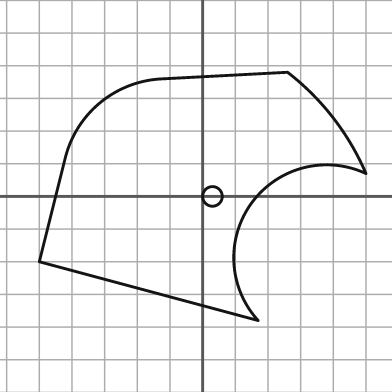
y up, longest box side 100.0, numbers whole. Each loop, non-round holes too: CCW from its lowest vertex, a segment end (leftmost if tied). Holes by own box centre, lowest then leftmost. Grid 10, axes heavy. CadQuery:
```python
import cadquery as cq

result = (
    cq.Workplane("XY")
    .moveTo(17.0, -38.0)
    .threePointArc((15.0, -2.0), (50.0, 7.0))
    .threePointArc((40.0, 24.0), (26.0, 38.0))
    .lineTo(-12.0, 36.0)
    .threePointArc((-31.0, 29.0), (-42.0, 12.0))
    .lineTo(-50.0, -20.0)
    .close()
    .moveTo(3.0, 0.0)
    .circle(3.0)
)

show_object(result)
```